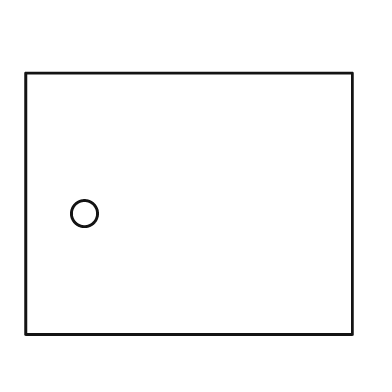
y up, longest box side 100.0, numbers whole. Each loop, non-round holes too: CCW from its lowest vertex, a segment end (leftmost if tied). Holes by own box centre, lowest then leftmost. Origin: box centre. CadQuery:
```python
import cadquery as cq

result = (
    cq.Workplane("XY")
    .moveTo(-50.0, -40.0)
    .lineTo(50.0, -40.0)
    .lineTo(50.0, 40.0)
    .lineTo(-50.0, 40.0)
    .close()
    .moveTo(-32.0, -3.0)
    .circle(4.0)
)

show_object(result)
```